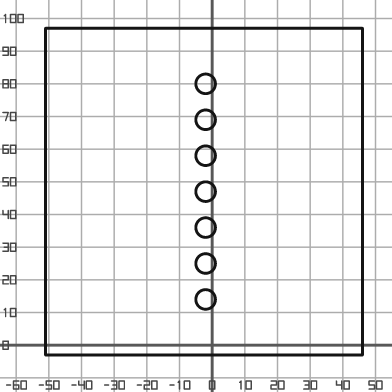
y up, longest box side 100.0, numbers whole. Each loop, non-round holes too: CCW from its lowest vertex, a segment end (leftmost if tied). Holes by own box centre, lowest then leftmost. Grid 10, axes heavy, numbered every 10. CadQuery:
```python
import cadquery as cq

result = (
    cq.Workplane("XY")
    .moveTo(-51.0, -3.0)
    .lineTo(46.0, -3.0)
    .lineTo(46.0, 97.0)
    .lineTo(-51.0, 97.0)
    .close()
    .moveTo(-2.0, 14.0)
    .circle(3.0)
    .moveTo(-2.0, 25.0)
    .circle(3.0)
    .moveTo(-2.0, 36.0)
    .circle(3.0)
    .moveTo(-2.0, 47.0)
    .circle(3.0)
    .moveTo(-2.0, 58.0)
    .circle(3.0)
    .moveTo(-2.0, 69.0)
    .circle(3.0)
    .moveTo(-2.0, 80.0)
    .circle(3.0)
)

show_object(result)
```